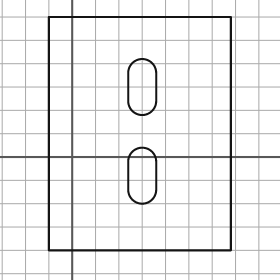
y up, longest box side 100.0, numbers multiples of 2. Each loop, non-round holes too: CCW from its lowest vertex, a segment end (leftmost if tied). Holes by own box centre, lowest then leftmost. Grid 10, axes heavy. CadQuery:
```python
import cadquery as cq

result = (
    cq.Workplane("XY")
    .moveTo(-10.0, -40.0)
    .lineTo(68.0, -40.0)
    .lineTo(68.0, 60.0)
    .lineTo(-10.0, 60.0)
    .close()
    .moveTo(24.0, -14.0)
    .threePointArc((30.0, -20.0), (36.0, -14.0))
    .lineTo(36.0, -2.0)
    .threePointArc((30.0, 4.0), (24.0, -2.0))
    .close()
    .moveTo(24.0, 24.0)
    .threePointArc((30.0, 18.0), (36.0, 24.0))
    .lineTo(36.0, 36.0)
    .threePointArc((30.0, 42.0), (24.0, 36.0))
    .close()
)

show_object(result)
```